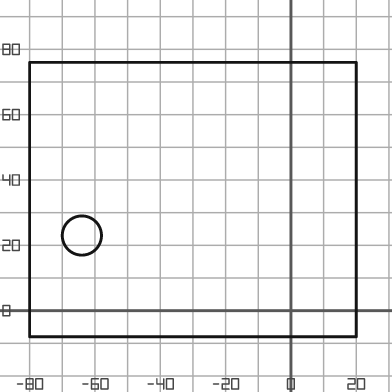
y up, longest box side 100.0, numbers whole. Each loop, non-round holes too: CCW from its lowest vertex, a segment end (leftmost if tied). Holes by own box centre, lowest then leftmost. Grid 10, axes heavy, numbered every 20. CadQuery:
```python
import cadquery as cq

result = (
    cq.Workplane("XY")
    .moveTo(-80.0, -8.0)
    .lineTo(20.0, -8.0)
    .lineTo(20.0, 76.0)
    .lineTo(-80.0, 76.0)
    .close()
    .moveTo(-64.0, 23.0)
    .circle(6.0)
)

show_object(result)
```